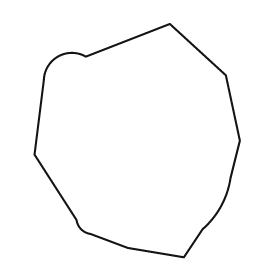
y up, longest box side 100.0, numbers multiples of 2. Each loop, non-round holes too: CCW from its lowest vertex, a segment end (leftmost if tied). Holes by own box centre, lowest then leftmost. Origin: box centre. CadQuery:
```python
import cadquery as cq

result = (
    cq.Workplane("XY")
    .moveTo(20.0, -50.0)
    .lineTo(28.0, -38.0)
    .threePointArc((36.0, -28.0), (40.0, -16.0))
    .lineTo(44.0, 0.0)
    .lineTo(38.0, 28.0)
    .lineTo(14.0, 50.0)
    .lineTo(-22.0, 36.0)
    .threePointArc((-34.0, 36.0), (-40.0, 26.0))
    .lineTo(-44.0, -6.0)
    .lineTo(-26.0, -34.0)
    .threePointArc((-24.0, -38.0), (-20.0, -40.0))
    .lineTo(-4.0, -46.0)
    .close()
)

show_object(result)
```